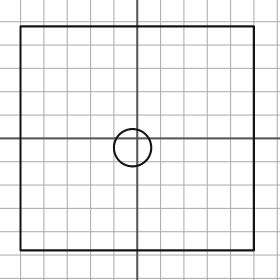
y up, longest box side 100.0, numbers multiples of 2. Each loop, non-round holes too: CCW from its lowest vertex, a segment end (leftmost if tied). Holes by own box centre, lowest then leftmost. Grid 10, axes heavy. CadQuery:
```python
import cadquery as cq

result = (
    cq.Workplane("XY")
    .moveTo(-50.0, -48.0)
    .lineTo(50.0, -48.0)
    .lineTo(50.0, 48.0)
    .lineTo(-50.0, 48.0)
    .close()
    .moveTo(-2.0, -4.0)
    .circle(8.0)
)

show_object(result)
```